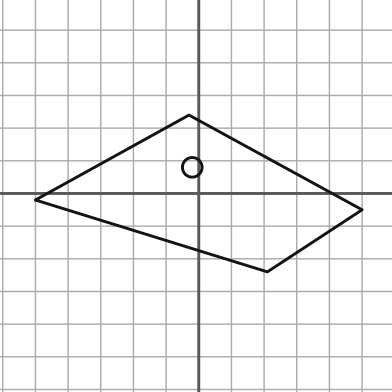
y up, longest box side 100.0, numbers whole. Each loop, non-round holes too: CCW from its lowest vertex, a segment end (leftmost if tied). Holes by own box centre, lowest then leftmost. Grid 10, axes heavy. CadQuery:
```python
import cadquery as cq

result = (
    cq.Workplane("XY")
    .moveTo(21.0, -24.0)
    .lineTo(50.0, -5.0)
    .lineTo(-3.0, 24.0)
    .lineTo(-50.0, -2.0)
    .close()
    .moveTo(-2.0, 8.0)
    .circle(3.0)
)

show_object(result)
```